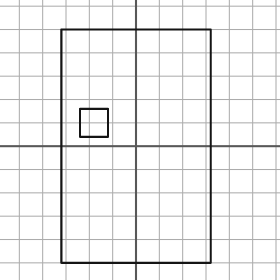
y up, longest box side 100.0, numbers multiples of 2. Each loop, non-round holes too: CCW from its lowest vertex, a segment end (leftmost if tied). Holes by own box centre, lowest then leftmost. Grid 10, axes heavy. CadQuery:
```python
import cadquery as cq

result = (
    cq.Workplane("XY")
    .moveTo(-32.0, -50.0)
    .lineTo(32.0, -50.0)
    .lineTo(32.0, 50.0)
    .lineTo(-32.0, 50.0)
    .close()
    .moveTo(-24.0, 4.0)
    .lineTo(-12.0, 4.0)
    .lineTo(-12.0, 16.0)
    .lineTo(-24.0, 16.0)
    .close()
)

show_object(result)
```